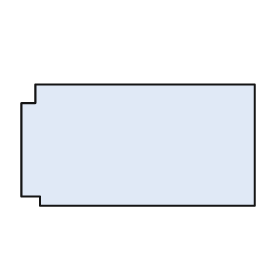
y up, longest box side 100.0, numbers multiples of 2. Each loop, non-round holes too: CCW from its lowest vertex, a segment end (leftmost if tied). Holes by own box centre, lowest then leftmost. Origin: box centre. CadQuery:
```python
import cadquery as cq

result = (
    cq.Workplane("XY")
    .moveTo(-42.0, -26.0)
    .lineTo(50.0, -26.0)
    .lineTo(50.0, 26.0)
    .lineTo(-44.0, 26.0)
    .lineTo(-44.0, 18.0)
    .lineTo(-50.0, 18.0)
    .lineTo(-50.0, -22.0)
    .lineTo(-42.0, -22.0)
    .close()
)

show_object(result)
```